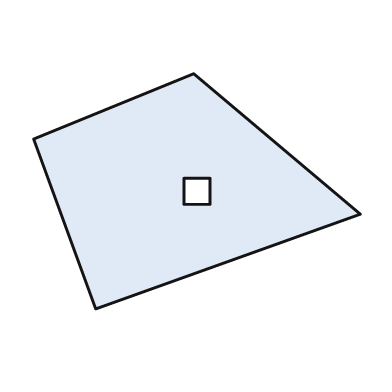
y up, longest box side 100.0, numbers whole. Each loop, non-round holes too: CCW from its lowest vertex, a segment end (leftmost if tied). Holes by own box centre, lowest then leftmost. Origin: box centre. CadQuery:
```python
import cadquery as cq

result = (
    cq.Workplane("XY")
    .moveTo(-31.0, -36.0)
    .lineTo(50.0, -7.0)
    .lineTo(-1.0, 36.0)
    .lineTo(-50.0, 16.0)
    .close()
    .moveTo(-4.0, -4.0)
    .lineTo(4.0, -4.0)
    .lineTo(4.0, 4.0)
    .lineTo(-4.0, 4.0)
    .close()
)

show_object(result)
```